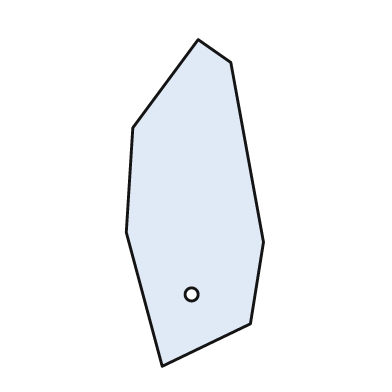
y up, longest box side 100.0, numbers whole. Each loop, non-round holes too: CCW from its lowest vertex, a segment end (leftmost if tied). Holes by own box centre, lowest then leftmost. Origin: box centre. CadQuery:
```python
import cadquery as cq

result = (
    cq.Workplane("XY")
    .moveTo(-10.0, -50.0)
    .lineTo(17.0, -37.0)
    .lineTo(21.0, -12.0)
    .lineTo(11.0, 43.0)
    .lineTo(1.0, 50.0)
    .lineTo(-19.0, 23.0)
    .lineTo(-21.0, -9.0)
    .close()
    .moveTo(-1.0, -28.0)
    .circle(2.0)
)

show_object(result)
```